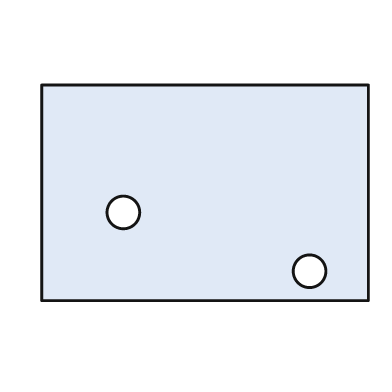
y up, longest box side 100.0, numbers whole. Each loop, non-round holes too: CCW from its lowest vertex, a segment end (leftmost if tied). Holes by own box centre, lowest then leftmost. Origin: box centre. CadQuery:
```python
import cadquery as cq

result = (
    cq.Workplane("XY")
    .moveTo(-50.0, -33.0)
    .lineTo(50.0, -33.0)
    .lineTo(50.0, 33.0)
    .lineTo(-50.0, 33.0)
    .close()
    .moveTo(32.0, -24.0)
    .circle(5.0)
    .moveTo(-25.0, -6.0)
    .circle(5.0)
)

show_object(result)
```